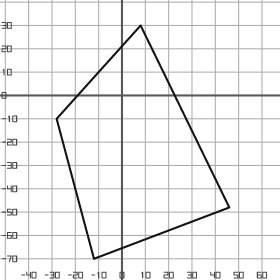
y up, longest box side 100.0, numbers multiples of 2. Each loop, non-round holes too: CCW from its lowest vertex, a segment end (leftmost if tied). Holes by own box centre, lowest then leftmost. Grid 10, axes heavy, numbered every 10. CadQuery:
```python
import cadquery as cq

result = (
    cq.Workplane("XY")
    .moveTo(-12.0, -70.0)
    .lineTo(46.0, -48.0)
    .lineTo(8.0, 30.0)
    .lineTo(-28.0, -10.0)
    .close()
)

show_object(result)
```